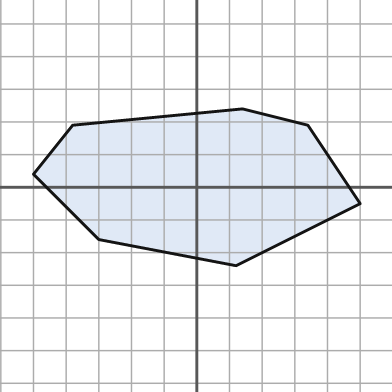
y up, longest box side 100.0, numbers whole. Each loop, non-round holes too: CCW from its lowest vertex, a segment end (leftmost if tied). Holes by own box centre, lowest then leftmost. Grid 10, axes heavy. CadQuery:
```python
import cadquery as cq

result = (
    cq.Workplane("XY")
    .moveTo(12.0, -24.0)
    .lineTo(50.0, -5.0)
    .lineTo(34.0, 19.0)
    .lineTo(14.0, 24.0)
    .lineTo(-38.0, 19.0)
    .lineTo(-50.0, 4.0)
    .lineTo(-30.0, -16.0)
    .close()
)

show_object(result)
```